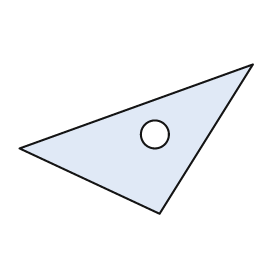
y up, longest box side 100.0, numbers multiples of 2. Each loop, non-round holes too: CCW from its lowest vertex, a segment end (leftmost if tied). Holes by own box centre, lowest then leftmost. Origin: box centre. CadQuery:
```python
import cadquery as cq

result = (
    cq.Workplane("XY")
    .moveTo(10.0, -32.0)
    .lineTo(50.0, 32.0)
    .lineTo(-50.0, -4.0)
    .close()
    .moveTo(8.0, 2.0)
    .circle(6.0)
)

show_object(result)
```